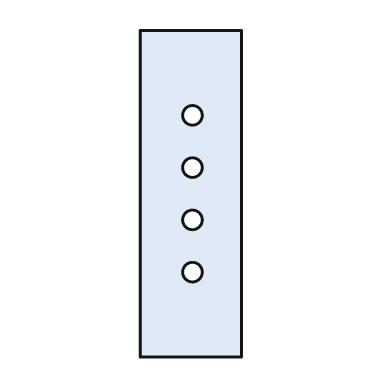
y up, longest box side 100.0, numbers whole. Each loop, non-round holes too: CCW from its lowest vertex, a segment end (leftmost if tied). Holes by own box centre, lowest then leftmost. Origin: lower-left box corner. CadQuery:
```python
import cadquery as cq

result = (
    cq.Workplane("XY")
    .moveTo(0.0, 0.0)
    .lineTo(31.0, 0.0)
    .lineTo(31.0, 100.0)
    .lineTo(0.0, 100.0)
    .close()
    .moveTo(16.0, 26.0)
    .circle(3.0)
    .moveTo(16.0, 42.0)
    .circle(3.0)
    .moveTo(16.0, 58.0)
    .circle(3.0)
    .moveTo(16.0, 74.0)
    .circle(3.0)
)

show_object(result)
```